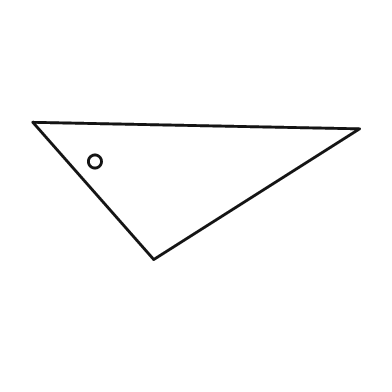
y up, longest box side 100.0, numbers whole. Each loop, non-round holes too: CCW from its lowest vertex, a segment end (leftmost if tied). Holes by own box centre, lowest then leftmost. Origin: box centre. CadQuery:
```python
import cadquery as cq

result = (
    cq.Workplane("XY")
    .moveTo(-13.0, -21.0)
    .lineTo(50.0, 19.0)
    .lineTo(-50.0, 21.0)
    .close()
    .moveTo(-31.0, 9.0)
    .circle(2.0)
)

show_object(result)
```